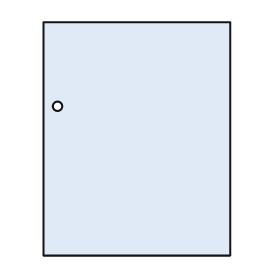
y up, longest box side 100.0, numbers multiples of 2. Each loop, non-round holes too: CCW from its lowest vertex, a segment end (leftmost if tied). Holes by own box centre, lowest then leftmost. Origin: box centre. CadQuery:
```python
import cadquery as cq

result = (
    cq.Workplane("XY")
    .moveTo(-40.0, -50.0)
    .lineTo(40.0, -50.0)
    .lineTo(40.0, 50.0)
    .lineTo(-40.0, 50.0)
    .close()
    .moveTo(-34.0, 14.0)
    .circle(2.0)
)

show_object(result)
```